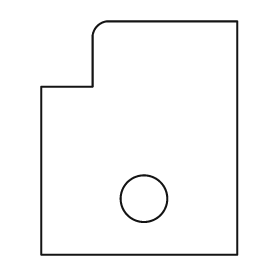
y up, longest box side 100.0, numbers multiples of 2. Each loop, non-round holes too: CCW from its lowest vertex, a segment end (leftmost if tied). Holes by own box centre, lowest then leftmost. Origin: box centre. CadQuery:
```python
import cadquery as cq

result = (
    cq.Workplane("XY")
    .moveTo(-42.0, -50.0)
    .lineTo(42.0, -50.0)
    .lineTo(42.0, 50.0)
    .lineTo(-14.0, 50.0)
    .threePointArc((-18.0, 48.0), (-20.0, 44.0))
    .lineTo(-20.0, 22.0)
    .lineTo(-42.0, 22.0)
    .close()
    .moveTo(2.0, -26.0)
    .circle(10.0)
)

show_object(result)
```